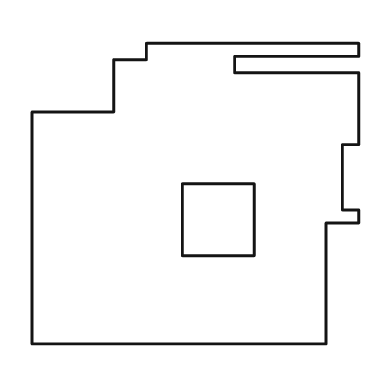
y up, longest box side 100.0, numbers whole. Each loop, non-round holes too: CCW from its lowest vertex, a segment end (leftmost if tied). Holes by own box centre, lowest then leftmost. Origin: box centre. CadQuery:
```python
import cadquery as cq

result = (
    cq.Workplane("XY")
    .moveTo(-50.0, -46.0)
    .lineTo(40.0, -46.0)
    .lineTo(40.0, -9.0)
    .lineTo(50.0, -9.0)
    .lineTo(50.0, -5.0)
    .lineTo(45.0, -5.0)
    .lineTo(45.0, 15.0)
    .lineTo(50.0, 15.0)
    .lineTo(50.0, 37.0)
    .lineTo(12.0, 37.0)
    .lineTo(12.0, 42.0)
    .lineTo(50.0, 42.0)
    .lineTo(50.0, 46.0)
    .lineTo(-15.0, 46.0)
    .lineTo(-15.0, 41.0)
    .lineTo(-25.0, 41.0)
    .lineTo(-25.0, 25.0)
    .lineTo(-50.0, 25.0)
    .close()
    .moveTo(-4.0, -19.0)
    .lineTo(18.0, -19.0)
    .lineTo(18.0, 3.0)
    .lineTo(-4.0, 3.0)
    .close()
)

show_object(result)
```